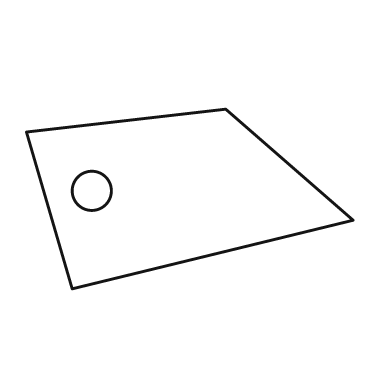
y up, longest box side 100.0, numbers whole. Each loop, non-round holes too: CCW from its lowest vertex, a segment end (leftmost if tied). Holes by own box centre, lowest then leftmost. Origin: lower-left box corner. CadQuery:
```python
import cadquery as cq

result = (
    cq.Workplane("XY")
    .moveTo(14.0, 0.0)
    .lineTo(100.0, 21.0)
    .lineTo(61.0, 55.0)
    .lineTo(0.0, 48.0)
    .close()
    .moveTo(20.0, 30.0)
    .circle(6.0)
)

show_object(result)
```